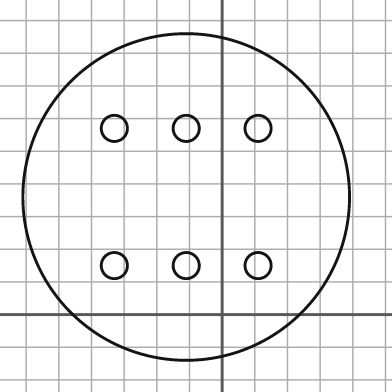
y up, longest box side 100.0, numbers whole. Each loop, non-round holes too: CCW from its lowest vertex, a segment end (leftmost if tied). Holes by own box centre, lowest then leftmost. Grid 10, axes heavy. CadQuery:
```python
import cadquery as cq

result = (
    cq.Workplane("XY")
    .moveTo(-11.0, 36.0)
    .circle(50.0)
    .moveTo(-33.0, 15.0)
    .circle(4.0)
    .moveTo(-11.0, 15.0)
    .circle(4.0)
    .moveTo(11.0, 15.0)
    .circle(4.0)
    .moveTo(-33.0, 57.0)
    .circle(4.0)
    .moveTo(-11.0, 57.0)
    .circle(4.0)
    .moveTo(11.0, 57.0)
    .circle(4.0)
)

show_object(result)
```